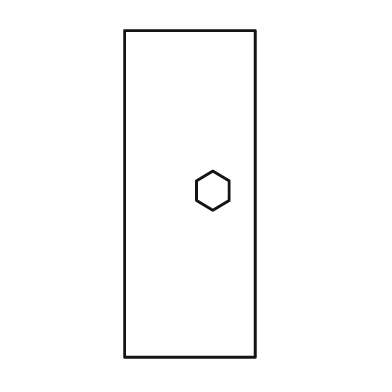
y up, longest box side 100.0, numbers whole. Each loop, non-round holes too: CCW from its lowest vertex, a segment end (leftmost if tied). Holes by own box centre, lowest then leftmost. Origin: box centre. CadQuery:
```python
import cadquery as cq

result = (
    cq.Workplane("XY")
    .moveTo(-20.0, -50.0)
    .lineTo(20.0, -50.0)
    .lineTo(20.0, 50.0)
    .lineTo(-20.0, 50.0)
    .close()
    .moveTo(7.0, -5.0)
    .lineTo(12.0, -2.0)
    .lineTo(12.0, 4.0)
    .lineTo(7.0, 7.0)
    .lineTo(2.0, 4.0)
    .lineTo(2.0, -2.0)
    .close()
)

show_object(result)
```